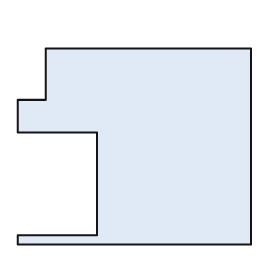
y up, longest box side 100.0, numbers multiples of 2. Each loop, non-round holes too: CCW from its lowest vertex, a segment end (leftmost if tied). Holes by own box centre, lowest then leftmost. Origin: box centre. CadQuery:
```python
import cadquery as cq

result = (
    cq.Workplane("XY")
    .moveTo(-50.0, -42.0)
    .lineTo(50.0, -42.0)
    .lineTo(50.0, 42.0)
    .lineTo(-38.0, 42.0)
    .lineTo(-38.0, 20.0)
    .lineTo(-50.0, 20.0)
    .lineTo(-50.0, 6.0)
    .lineTo(-16.0, 6.0)
    .lineTo(-16.0, -38.0)
    .lineTo(-50.0, -38.0)
    .close()
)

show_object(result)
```